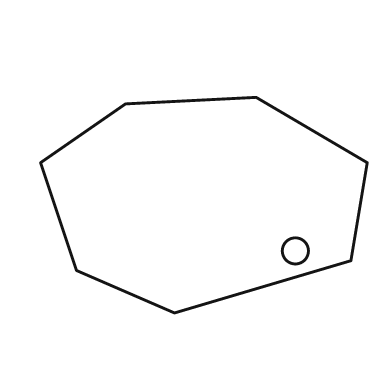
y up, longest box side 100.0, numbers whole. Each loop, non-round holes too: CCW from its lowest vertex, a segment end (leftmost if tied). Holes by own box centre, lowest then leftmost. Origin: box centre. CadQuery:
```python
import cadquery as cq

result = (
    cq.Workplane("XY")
    .moveTo(-9.0, -33.0)
    .lineTo(45.0, -17.0)
    .lineTo(50.0, 13.0)
    .lineTo(16.0, 33.0)
    .lineTo(-24.0, 31.0)
    .lineTo(-50.0, 13.0)
    .lineTo(-39.0, -20.0)
    .close()
    .moveTo(28.0, -14.0)
    .circle(4.0)
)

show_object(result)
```